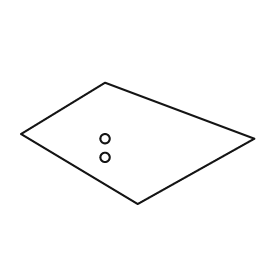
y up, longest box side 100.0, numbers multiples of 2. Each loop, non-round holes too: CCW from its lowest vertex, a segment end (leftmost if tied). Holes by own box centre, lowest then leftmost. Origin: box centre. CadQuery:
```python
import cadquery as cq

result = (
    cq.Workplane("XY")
    .moveTo(0.0, -26.0)
    .lineTo(50.0, 2.0)
    .lineTo(-14.0, 26.0)
    .lineTo(-50.0, 4.0)
    .close()
    .moveTo(-14.0, -6.0)
    .circle(2.0)
    .moveTo(-14.0, 2.0)
    .circle(2.0)
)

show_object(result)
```